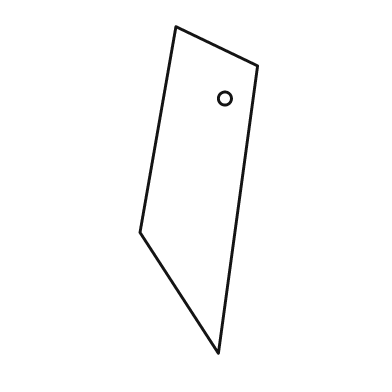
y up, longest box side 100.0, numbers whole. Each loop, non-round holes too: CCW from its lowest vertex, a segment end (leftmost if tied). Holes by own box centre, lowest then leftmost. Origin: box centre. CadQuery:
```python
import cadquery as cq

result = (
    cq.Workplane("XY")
    .moveTo(6.0, -50.0)
    .lineTo(18.0, 38.0)
    .lineTo(-7.0, 50.0)
    .lineTo(-18.0, -13.0)
    .close()
    .moveTo(8.0, 28.0)
    .circle(2.0)
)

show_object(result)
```